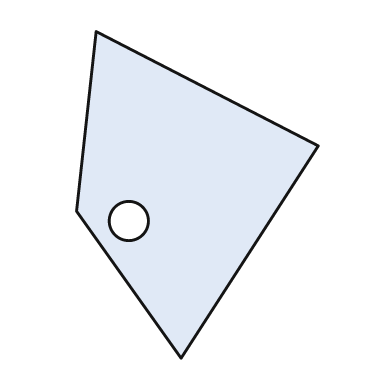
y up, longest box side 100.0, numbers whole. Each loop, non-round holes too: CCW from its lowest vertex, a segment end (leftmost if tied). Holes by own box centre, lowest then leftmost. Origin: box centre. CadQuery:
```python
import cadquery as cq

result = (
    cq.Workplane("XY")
    .moveTo(-5.0, -50.0)
    .lineTo(37.0, 15.0)
    .lineTo(-31.0, 50.0)
    .lineTo(-37.0, -5.0)
    .close()
    .moveTo(-21.0, -8.0)
    .circle(6.0)
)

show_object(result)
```